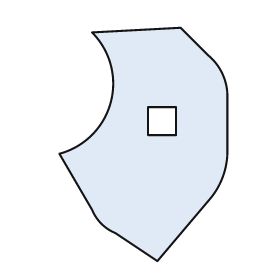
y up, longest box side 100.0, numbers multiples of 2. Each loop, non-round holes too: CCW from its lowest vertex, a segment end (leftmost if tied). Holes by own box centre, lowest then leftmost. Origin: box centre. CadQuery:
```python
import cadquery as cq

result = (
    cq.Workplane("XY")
    .moveTo(6.0, -50.0)
    .lineTo(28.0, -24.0)
    .threePointArc((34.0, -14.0), (36.0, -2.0))
    .lineTo(36.0, 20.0)
    .threePointArc((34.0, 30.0), (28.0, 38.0))
    .lineTo(16.0, 50.0)
    .lineTo(-22.0, 48.0)
    .threePointArc((-14.0, 18.0), (-36.0, -4.0))
    .lineTo(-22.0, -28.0)
    .threePointArc((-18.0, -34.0), (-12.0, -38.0))
    .close()
    .moveTo(2.0, 4.0)
    .lineTo(14.0, 4.0)
    .lineTo(14.0, 16.0)
    .lineTo(2.0, 16.0)
    .close()
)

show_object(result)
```